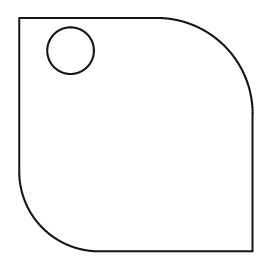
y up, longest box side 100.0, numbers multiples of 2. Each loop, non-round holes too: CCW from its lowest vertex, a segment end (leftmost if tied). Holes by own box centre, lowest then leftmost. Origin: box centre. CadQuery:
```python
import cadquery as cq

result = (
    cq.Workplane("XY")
    .moveTo(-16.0, -50.0)
    .lineTo(50.0, -50.0)
    .lineTo(50.0, 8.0)
    .threePointArc((38.0, 38.0), (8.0, 50.0))
    .lineTo(-50.0, 50.0)
    .lineTo(-50.0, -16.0)
    .threePointArc((-40.0, -40.0), (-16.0, -50.0))
    .close()
    .moveTo(-28.0, 36.0)
    .circle(10.0)
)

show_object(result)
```